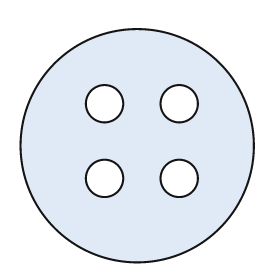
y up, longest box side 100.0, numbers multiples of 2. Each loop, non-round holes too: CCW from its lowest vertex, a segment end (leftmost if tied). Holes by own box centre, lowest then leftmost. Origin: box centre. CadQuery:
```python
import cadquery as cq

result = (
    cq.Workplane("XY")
    .moveTo(0.0, 0.0)
    .circle(50.0)
    .moveTo(-14.0, -14.0)
    .circle(8.0)
    .moveTo(18.0, -14.0)
    .circle(8.0)
    .moveTo(-14.0, 18.0)
    .circle(8.0)
    .moveTo(18.0, 18.0)
    .circle(8.0)
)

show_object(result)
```